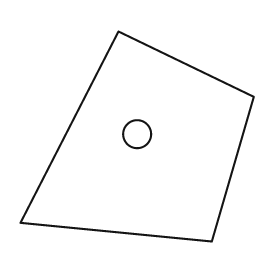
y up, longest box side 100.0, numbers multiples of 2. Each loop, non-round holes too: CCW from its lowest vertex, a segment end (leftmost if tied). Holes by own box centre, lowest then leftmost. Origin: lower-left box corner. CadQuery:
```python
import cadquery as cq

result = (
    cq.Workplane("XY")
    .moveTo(82.0, 0.0)
    .lineTo(100.0, 62.0)
    .lineTo(42.0, 90.0)
    .lineTo(0.0, 8.0)
    .close()
    .moveTo(50.0, 46.0)
    .circle(6.0)
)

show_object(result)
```